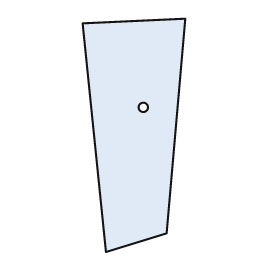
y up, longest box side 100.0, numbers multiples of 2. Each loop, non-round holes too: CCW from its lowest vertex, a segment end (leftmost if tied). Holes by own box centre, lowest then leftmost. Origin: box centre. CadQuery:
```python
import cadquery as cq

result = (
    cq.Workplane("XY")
    .moveTo(-12.0, -50.0)
    .lineTo(14.0, -42.0)
    .lineTo(22.0, 50.0)
    .lineTo(-22.0, 48.0)
    .close()
    .moveTo(4.0, 12.0)
    .circle(2.0)
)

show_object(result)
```